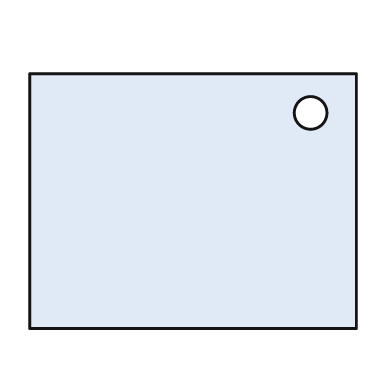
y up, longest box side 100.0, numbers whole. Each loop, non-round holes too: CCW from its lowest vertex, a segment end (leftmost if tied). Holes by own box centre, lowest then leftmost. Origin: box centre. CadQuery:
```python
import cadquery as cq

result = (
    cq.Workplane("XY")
    .moveTo(-50.0, -39.0)
    .lineTo(50.0, -39.0)
    .lineTo(50.0, 39.0)
    .lineTo(-50.0, 39.0)
    .close()
    .moveTo(36.0, 27.0)
    .circle(5.0)
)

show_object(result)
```